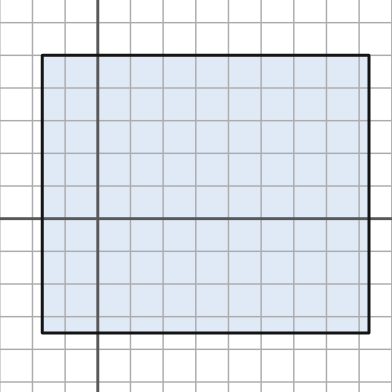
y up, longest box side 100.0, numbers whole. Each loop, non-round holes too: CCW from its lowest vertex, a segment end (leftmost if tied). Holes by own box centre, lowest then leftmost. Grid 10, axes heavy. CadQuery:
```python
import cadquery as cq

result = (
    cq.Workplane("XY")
    .moveTo(-17.0, -35.0)
    .lineTo(83.0, -35.0)
    .lineTo(83.0, 50.0)
    .lineTo(-17.0, 50.0)
    .close()
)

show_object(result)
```